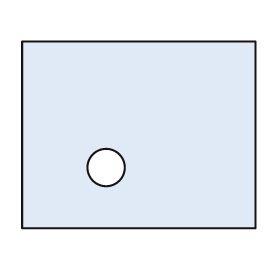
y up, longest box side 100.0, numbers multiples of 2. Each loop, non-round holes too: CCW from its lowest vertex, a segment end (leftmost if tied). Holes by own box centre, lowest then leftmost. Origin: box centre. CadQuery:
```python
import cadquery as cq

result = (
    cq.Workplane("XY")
    .moveTo(-50.0, -40.0)
    .lineTo(50.0, -40.0)
    .lineTo(50.0, 40.0)
    .lineTo(-50.0, 40.0)
    .close()
    .moveTo(-14.0, -14.0)
    .circle(8.0)
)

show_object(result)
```